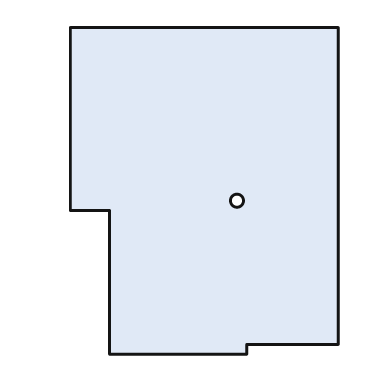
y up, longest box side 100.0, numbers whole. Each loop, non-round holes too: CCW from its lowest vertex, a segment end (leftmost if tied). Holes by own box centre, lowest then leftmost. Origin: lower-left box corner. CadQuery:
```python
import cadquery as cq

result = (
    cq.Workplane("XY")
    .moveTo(12.0, 0.0)
    .lineTo(54.0, 0.0)
    .lineTo(54.0, 3.0)
    .lineTo(82.0, 3.0)
    .lineTo(82.0, 100.0)
    .lineTo(0.0, 100.0)
    .lineTo(0.0, 44.0)
    .lineTo(12.0, 44.0)
    .close()
    .moveTo(51.0, 47.0)
    .circle(2.0)
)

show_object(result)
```